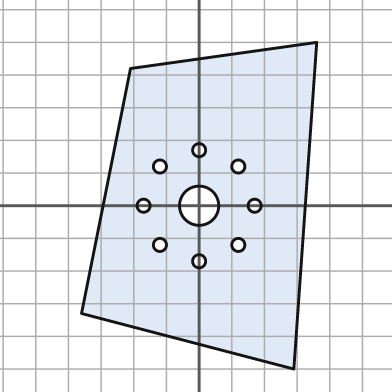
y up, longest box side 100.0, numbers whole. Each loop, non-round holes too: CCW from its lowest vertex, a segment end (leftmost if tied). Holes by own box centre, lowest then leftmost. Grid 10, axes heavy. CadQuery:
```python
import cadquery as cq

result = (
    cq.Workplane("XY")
    .moveTo(29.0, -50.0)
    .lineTo(36.0, 50.0)
    .lineTo(-21.0, 42.0)
    .lineTo(-36.0, -33.0)
    .close()
    .moveTo(0.0, -17.0)
    .circle(2.0)
    .moveTo(-12.0, -12.0)
    .circle(2.0)
    .moveTo(12.0, -12.0)
    .circle(2.0)
    .moveTo(-17.0, 0.0)
    .circle(2.0)
    .moveTo(0.0, 0.0)
    .circle(6.0)
    .moveTo(17.0, 0.0)
    .circle(2.0)
    .moveTo(-12.0, 12.0)
    .circle(2.0)
    .moveTo(12.0, 12.0)
    .circle(2.0)
    .moveTo(0.0, 17.0)
    .circle(2.0)
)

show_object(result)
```